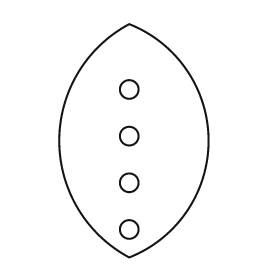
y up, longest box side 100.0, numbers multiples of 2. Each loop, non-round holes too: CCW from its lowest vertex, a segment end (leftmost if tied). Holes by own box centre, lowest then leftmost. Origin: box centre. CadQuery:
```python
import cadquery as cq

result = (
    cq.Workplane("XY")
    .moveTo(-2.0, -50.0)
    .threePointArc((32.0, 0.0), (-2.0, 50.0))
    .threePointArc((-32.0, 0.0), (-2.0, -50.0))
    .close()
    .moveTo(-2.0, -38.0)
    .circle(4.0)
    .moveTo(-2.0, -18.0)
    .circle(4.0)
    .moveTo(-2.0, 2.0)
    .circle(4.0)
    .moveTo(-2.0, 22.0)
    .circle(4.0)
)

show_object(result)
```